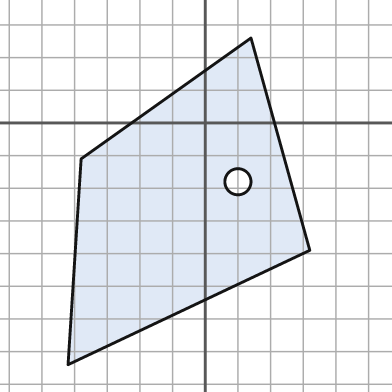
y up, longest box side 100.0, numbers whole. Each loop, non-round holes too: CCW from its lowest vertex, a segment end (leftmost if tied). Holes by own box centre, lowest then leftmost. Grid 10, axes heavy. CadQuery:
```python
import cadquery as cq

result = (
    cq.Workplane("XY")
    .moveTo(-42.0, -74.0)
    .lineTo(32.0, -39.0)
    .lineTo(14.0, 26.0)
    .lineTo(-38.0, -11.0)
    .close()
    .moveTo(10.0, -18.0)
    .circle(4.0)
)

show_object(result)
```